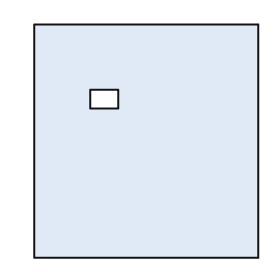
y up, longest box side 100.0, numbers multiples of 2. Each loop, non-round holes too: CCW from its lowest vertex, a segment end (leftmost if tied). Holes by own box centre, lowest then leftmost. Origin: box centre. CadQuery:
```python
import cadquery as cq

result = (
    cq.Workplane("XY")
    .moveTo(-48.0, -50.0)
    .lineTo(48.0, -50.0)
    .lineTo(48.0, 50.0)
    .lineTo(-48.0, 50.0)
    .close()
    .moveTo(-24.0, 14.0)
    .lineTo(-12.0, 14.0)
    .lineTo(-12.0, 22.0)
    .lineTo(-24.0, 22.0)
    .close()
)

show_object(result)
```